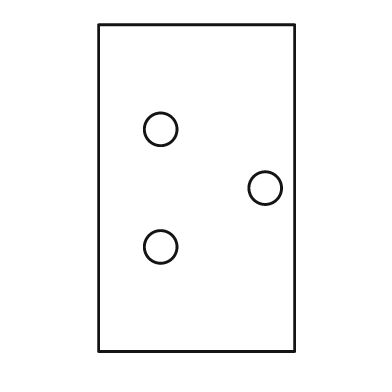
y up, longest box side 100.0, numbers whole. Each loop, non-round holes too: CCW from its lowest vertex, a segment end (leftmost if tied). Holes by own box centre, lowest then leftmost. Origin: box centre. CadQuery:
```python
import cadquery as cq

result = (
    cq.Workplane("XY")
    .moveTo(-30.0, -50.0)
    .lineTo(30.0, -50.0)
    .lineTo(30.0, 50.0)
    .lineTo(-30.0, 50.0)
    .close()
    .moveTo(-11.0, -18.0)
    .circle(5.0)
    .moveTo(21.0, 0.0)
    .circle(5.0)
    .moveTo(-11.0, 18.0)
    .circle(5.0)
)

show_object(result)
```